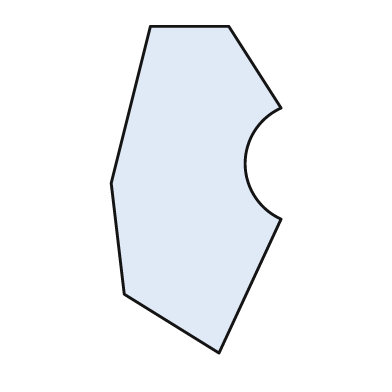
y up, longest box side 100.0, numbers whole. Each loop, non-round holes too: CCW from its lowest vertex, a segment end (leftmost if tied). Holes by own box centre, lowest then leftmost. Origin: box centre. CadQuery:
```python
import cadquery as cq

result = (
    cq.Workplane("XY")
    .moveTo(7.0, -50.0)
    .lineTo(26.0, -9.0)
    .threePointArc((15.0, 8.0), (26.0, 25.0))
    .lineTo(10.0, 50.0)
    .lineTo(-14.0, 50.0)
    .lineTo(-26.0, 2.0)
    .lineTo(-22.0, -32.0)
    .close()
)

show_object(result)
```